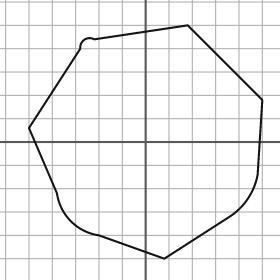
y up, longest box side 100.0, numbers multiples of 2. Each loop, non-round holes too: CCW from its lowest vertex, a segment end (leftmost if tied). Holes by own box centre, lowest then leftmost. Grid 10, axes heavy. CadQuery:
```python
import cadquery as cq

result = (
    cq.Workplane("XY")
    .moveTo(8.0, -50.0)
    .lineTo(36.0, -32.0)
    .threePointArc((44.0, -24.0), (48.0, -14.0))
    .lineTo(50.0, 18.0)
    .lineTo(18.0, 50.0)
    .lineTo(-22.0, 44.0)
    .threePointArc((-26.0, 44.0), (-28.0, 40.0))
    .lineTo(-50.0, 6.0)
    .lineTo(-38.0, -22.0)
    .threePointArc((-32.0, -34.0), (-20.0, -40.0))
    .close()
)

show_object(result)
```